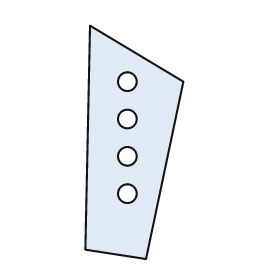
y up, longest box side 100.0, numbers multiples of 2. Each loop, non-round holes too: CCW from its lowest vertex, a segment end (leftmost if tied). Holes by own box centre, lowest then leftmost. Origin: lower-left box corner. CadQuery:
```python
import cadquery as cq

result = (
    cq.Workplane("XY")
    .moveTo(26.0, 0.0)
    .lineTo(42.0, 76.0)
    .lineTo(2.0, 100.0)
    .lineTo(0.0, 4.0)
    .close()
    .moveTo(18.0, 28.0)
    .circle(4.0)
    .moveTo(18.0, 44.0)
    .circle(4.0)
    .moveTo(18.0, 60.0)
    .circle(4.0)
    .moveTo(18.0, 76.0)
    .circle(4.0)
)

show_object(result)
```